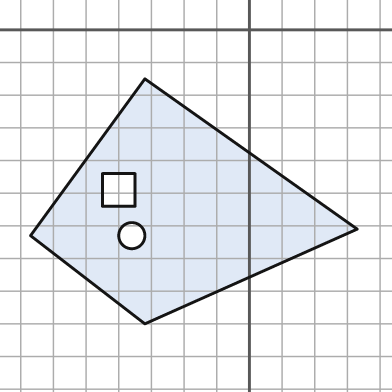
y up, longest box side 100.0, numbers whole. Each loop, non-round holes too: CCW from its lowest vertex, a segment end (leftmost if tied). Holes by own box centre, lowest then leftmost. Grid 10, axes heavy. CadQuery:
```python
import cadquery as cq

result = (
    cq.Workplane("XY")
    .moveTo(-32.0, -90.0)
    .lineTo(33.0, -61.0)
    .lineTo(-32.0, -15.0)
    .lineTo(-67.0, -63.0)
    .close()
    .moveTo(-36.0, -63.0)
    .circle(4.0)
    .moveTo(-45.0, -54.0)
    .lineTo(-35.0, -54.0)
    .lineTo(-35.0, -44.0)
    .lineTo(-45.0, -44.0)
    .close()
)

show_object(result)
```